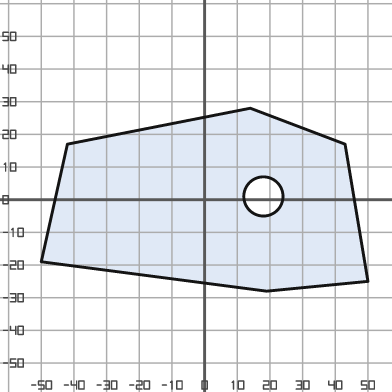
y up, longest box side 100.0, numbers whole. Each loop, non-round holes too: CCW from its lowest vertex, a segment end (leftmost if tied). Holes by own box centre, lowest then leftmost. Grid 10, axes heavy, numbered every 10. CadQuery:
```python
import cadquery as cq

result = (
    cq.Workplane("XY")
    .moveTo(19.0, -28.0)
    .lineTo(50.0, -25.0)
    .lineTo(43.0, 17.0)
    .lineTo(14.0, 28.0)
    .lineTo(-42.0, 17.0)
    .lineTo(-50.0, -19.0)
    .close()
    .moveTo(18.0, 1.0)
    .circle(6.0)
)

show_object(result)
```